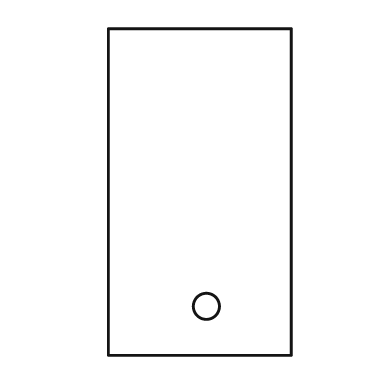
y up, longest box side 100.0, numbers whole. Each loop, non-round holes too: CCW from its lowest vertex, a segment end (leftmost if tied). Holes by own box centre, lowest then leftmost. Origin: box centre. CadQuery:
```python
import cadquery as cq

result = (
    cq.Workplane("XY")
    .moveTo(-28.0, -50.0)
    .lineTo(28.0, -50.0)
    .lineTo(28.0, 50.0)
    .lineTo(-28.0, 50.0)
    .close()
    .moveTo(2.0, -35.0)
    .circle(4.0)
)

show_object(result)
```